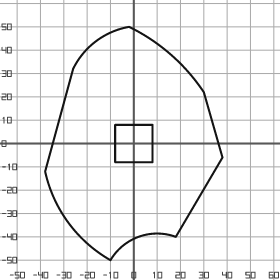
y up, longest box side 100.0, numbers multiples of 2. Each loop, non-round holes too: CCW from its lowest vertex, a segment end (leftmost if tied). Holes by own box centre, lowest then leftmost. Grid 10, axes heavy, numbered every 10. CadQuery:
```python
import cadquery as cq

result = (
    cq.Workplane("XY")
    .moveTo(-10.0, -50.0)
    .threePointArc((2.0, -40.0), (18.0, -40.0))
    .lineTo(38.0, -6.0)
    .lineTo(30.0, 22.0)
    .threePointArc((16.0, 38.0), (-2.0, 50.0))
    .threePointArc((-16.0, 44.0), (-26.0, 32.0))
    .lineTo(-38.0, -12.0)
    .threePointArc((-28.0, -34.0), (-10.0, -50.0))
    .close()
    .moveTo(-8.0, -8.0)
    .lineTo(8.0, -8.0)
    .lineTo(8.0, 8.0)
    .lineTo(-8.0, 8.0)
    .close()
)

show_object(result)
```